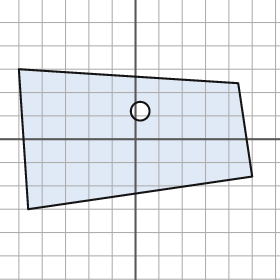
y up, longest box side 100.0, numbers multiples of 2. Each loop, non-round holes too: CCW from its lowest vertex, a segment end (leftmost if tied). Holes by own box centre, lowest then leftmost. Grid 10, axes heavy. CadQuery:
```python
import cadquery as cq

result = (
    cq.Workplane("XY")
    .moveTo(-46.0, -30.0)
    .lineTo(50.0, -16.0)
    .lineTo(44.0, 24.0)
    .lineTo(-50.0, 30.0)
    .close()
    .moveTo(2.0, 12.0)
    .circle(4.0)
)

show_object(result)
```